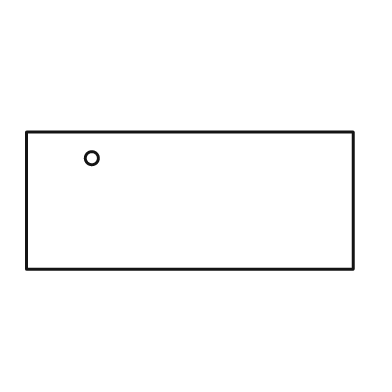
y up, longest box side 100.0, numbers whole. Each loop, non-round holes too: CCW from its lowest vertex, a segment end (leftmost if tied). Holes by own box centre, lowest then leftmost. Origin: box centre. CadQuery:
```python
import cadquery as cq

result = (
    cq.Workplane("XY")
    .moveTo(-50.0, -21.0)
    .lineTo(50.0, -21.0)
    .lineTo(50.0, 21.0)
    .lineTo(-50.0, 21.0)
    .close()
    .moveTo(-30.0, 13.0)
    .circle(2.0)
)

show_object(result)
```